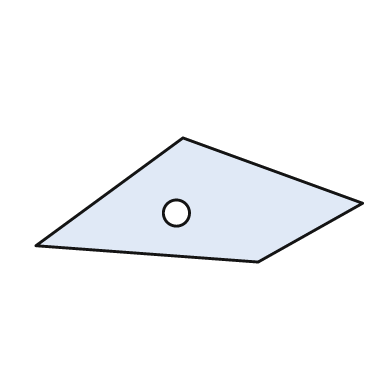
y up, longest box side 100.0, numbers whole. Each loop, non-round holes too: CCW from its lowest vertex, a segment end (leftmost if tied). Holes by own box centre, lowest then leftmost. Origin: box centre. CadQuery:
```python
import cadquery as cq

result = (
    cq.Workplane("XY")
    .moveTo(18.0, -19.0)
    .lineTo(50.0, -1.0)
    .lineTo(-5.0, 19.0)
    .lineTo(-50.0, -14.0)
    .close()
    .moveTo(-7.0, -4.0)
    .circle(4.0)
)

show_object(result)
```